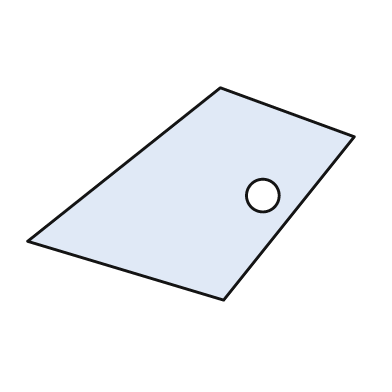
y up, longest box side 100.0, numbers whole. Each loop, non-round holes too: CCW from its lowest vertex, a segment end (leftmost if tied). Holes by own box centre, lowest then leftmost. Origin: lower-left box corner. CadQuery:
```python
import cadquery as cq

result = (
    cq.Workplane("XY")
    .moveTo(60.0, 0.0)
    .lineTo(100.0, 50.0)
    .lineTo(59.0, 65.0)
    .lineTo(0.0, 18.0)
    .close()
    .moveTo(72.0, 32.0)
    .circle(5.0)
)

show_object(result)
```